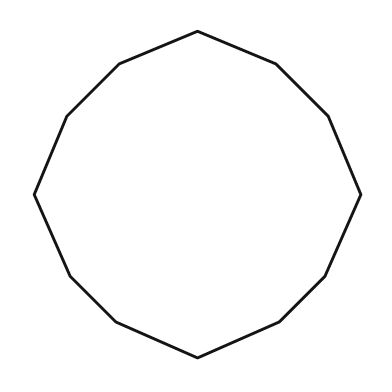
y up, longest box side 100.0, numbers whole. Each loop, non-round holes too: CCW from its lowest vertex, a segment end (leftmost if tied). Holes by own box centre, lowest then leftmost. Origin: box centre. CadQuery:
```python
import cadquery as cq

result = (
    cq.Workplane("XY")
    .moveTo(0.0, -50.0)
    .lineTo(25.0, -39.0)
    .lineTo(39.0, -25.0)
    .lineTo(50.0, 0.0)
    .lineTo(40.0, 24.0)
    .lineTo(24.0, 40.0)
    .lineTo(0.0, 50.0)
    .lineTo(-24.0, 40.0)
    .lineTo(-40.0, 24.0)
    .lineTo(-50.0, 0.0)
    .lineTo(-39.0, -25.0)
    .lineTo(-25.0, -39.0)
    .close()
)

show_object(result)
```